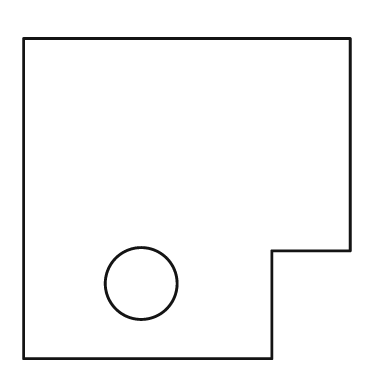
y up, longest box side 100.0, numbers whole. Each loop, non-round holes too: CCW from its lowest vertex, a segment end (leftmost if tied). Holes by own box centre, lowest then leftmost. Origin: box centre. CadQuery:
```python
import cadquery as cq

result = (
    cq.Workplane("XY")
    .moveTo(-50.0, -49.0)
    .lineTo(26.0, -49.0)
    .lineTo(26.0, -16.0)
    .lineTo(50.0, -16.0)
    .lineTo(50.0, 49.0)
    .lineTo(-50.0, 49.0)
    .close()
    .moveTo(-14.0, -26.0)
    .circle(11.0)
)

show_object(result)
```